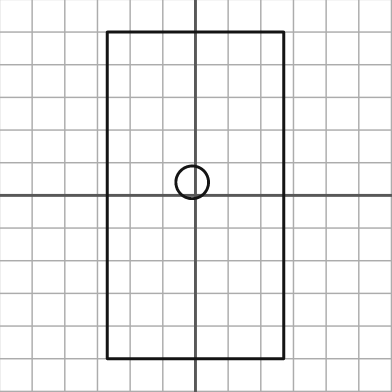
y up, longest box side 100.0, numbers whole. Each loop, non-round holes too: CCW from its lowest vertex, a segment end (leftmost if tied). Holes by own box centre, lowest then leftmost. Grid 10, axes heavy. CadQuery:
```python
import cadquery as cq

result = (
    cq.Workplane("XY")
    .moveTo(-27.0, -50.0)
    .lineTo(27.0, -50.0)
    .lineTo(27.0, 50.0)
    .lineTo(-27.0, 50.0)
    .close()
    .moveTo(-1.0, 4.0)
    .circle(5.0)
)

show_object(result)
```